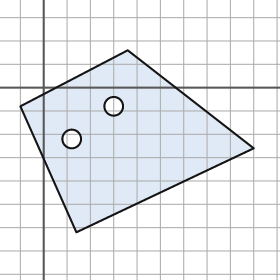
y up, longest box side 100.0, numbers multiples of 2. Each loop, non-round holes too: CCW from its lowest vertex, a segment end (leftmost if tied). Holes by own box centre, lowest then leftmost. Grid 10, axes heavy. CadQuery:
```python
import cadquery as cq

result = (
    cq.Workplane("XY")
    .moveTo(14.0, -62.0)
    .lineTo(90.0, -26.0)
    .lineTo(36.0, 16.0)
    .lineTo(-10.0, -8.0)
    .close()
    .moveTo(12.0, -22.0)
    .circle(4.0)
    .moveTo(30.0, -8.0)
    .circle(4.0)
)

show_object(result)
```